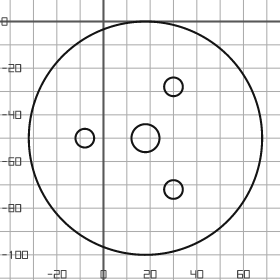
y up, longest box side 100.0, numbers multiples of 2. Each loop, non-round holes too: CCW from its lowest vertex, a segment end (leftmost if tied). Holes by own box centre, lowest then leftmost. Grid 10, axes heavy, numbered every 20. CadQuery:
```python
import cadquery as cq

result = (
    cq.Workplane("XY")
    .moveTo(18.0, -50.0)
    .circle(50.0)
    .moveTo(30.0, -72.0)
    .circle(4.0)
    .moveTo(-8.0, -50.0)
    .circle(4.0)
    .moveTo(18.0, -50.0)
    .circle(6.0)
    .moveTo(30.0, -28.0)
    .circle(4.0)
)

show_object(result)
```